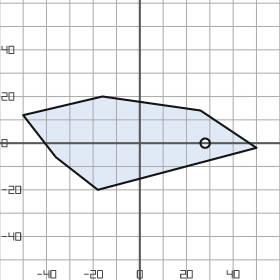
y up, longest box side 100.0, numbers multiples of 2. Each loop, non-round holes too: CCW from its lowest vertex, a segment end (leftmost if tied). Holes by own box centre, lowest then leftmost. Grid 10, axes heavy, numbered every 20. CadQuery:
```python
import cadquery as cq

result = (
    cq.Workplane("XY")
    .moveTo(-18.0, -20.0)
    .lineTo(50.0, -2.0)
    .lineTo(26.0, 14.0)
    .lineTo(-16.0, 20.0)
    .lineTo(-50.0, 12.0)
    .lineTo(-36.0, -6.0)
    .close()
    .moveTo(28.0, 0.0)
    .circle(2.0)
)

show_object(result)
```